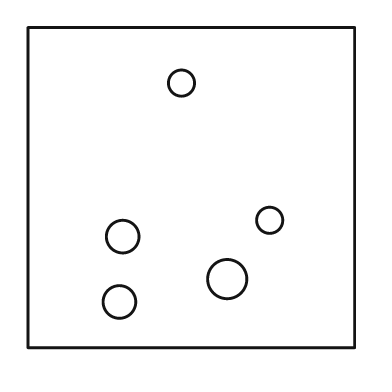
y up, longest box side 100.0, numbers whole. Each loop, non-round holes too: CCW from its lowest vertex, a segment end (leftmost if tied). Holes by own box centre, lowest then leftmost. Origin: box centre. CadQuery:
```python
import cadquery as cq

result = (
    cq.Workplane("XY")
    .moveTo(-50.0, -49.0)
    .lineTo(50.0, -49.0)
    .lineTo(50.0, 49.0)
    .lineTo(-50.0, 49.0)
    .close()
    .moveTo(-22.0, -35.0)
    .circle(5.0)
    .moveTo(11.0, -28.0)
    .circle(6.0)
    .moveTo(-21.0, -15.0)
    .circle(5.0)
    .moveTo(24.0, -10.0)
    .circle(4.0)
    .moveTo(-3.0, 32.0)
    .circle(4.0)
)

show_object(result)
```